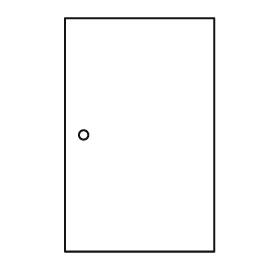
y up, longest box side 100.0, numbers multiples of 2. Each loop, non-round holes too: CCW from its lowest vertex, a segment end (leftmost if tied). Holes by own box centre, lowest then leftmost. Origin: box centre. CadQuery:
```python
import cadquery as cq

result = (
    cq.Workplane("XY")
    .moveTo(-32.0, -50.0)
    .lineTo(32.0, -50.0)
    .lineTo(32.0, 50.0)
    .lineTo(-32.0, 50.0)
    .close()
    .moveTo(-24.0, 0.0)
    .circle(2.0)
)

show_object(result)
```